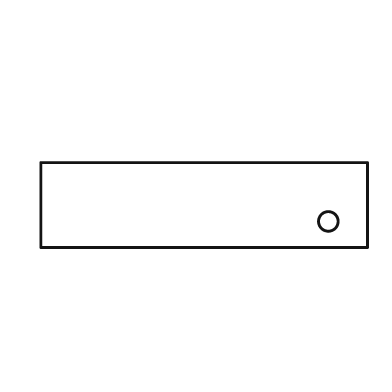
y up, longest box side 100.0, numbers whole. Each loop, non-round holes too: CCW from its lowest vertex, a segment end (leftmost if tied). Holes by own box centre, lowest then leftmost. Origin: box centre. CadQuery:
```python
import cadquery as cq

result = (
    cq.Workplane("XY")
    .moveTo(-50.0, -13.0)
    .lineTo(50.0, -13.0)
    .lineTo(50.0, 13.0)
    .lineTo(-50.0, 13.0)
    .close()
    .moveTo(38.0, -5.0)
    .circle(3.0)
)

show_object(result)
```